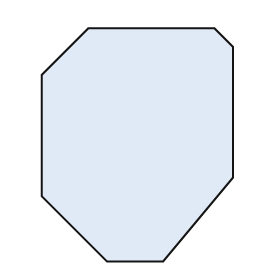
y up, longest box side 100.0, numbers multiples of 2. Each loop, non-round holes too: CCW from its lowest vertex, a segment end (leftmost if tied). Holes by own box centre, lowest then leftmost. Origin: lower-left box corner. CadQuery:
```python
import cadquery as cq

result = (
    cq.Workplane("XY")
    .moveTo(28.0, 0.0)
    .lineTo(52.0, 0.0)
    .lineTo(82.0, 36.0)
    .lineTo(82.0, 92.0)
    .lineTo(74.0, 100.0)
    .lineTo(20.0, 100.0)
    .lineTo(0.0, 80.0)
    .lineTo(0.0, 28.0)
    .close()
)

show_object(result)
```